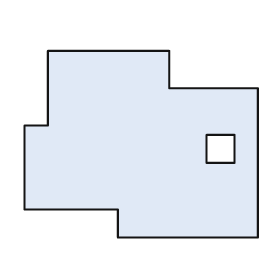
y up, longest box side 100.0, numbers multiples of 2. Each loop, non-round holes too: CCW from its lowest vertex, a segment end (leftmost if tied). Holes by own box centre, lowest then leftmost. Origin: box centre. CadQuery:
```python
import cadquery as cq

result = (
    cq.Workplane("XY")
    .moveTo(-10.0, -40.0)
    .lineTo(50.0, -40.0)
    .lineTo(50.0, 24.0)
    .lineTo(12.0, 24.0)
    .lineTo(12.0, 40.0)
    .lineTo(-40.0, 40.0)
    .lineTo(-40.0, 8.0)
    .lineTo(-50.0, 8.0)
    .lineTo(-50.0, -28.0)
    .lineTo(-10.0, -28.0)
    .close()
    .moveTo(28.0, -8.0)
    .lineTo(40.0, -8.0)
    .lineTo(40.0, 4.0)
    .lineTo(28.0, 4.0)
    .close()
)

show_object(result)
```